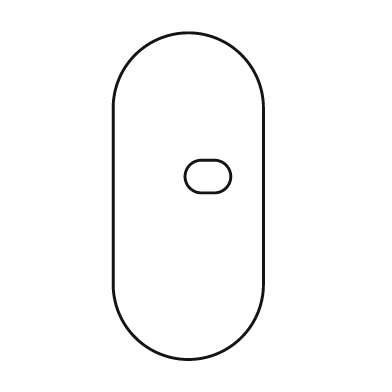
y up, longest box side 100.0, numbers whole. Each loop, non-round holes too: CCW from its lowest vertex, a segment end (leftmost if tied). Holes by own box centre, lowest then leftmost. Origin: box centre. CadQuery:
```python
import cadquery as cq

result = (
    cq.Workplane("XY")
    .moveTo(-23.0, -27.0)
    .threePointArc((0.0, -50.0), (23.0, -27.0))
    .lineTo(23.0, 27.0)
    .threePointArc((0.0, 50.0), (-23.0, 27.0))
    .close()
    .moveTo(4.0, 1.0)
    .lineTo(8.0, 1.0)
    .threePointArc((13.0, 6.0), (8.0, 11.0))
    .lineTo(4.0, 11.0)
    .threePointArc((-1.0, 6.0), (4.0, 1.0))
    .close()
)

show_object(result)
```